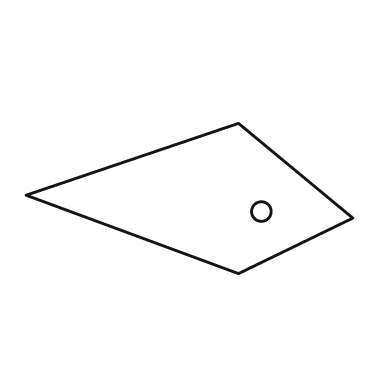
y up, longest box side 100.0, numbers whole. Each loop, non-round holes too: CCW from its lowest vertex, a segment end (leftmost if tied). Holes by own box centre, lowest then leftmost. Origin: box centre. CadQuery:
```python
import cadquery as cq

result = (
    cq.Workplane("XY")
    .moveTo(15.0, -23.0)
    .lineTo(50.0, -6.0)
    .lineTo(15.0, 23.0)
    .lineTo(-50.0, 1.0)
    .close()
    .moveTo(22.0, -4.0)
    .circle(3.0)
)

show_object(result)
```